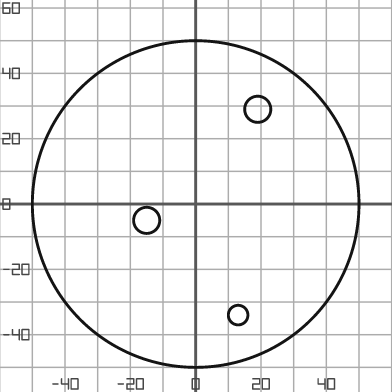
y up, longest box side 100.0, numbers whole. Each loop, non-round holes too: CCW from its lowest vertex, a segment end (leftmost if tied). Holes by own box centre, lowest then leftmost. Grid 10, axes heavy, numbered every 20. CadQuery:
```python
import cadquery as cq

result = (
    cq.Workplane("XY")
    .moveTo(0.0, 0.0)
    .circle(50.0)
    .moveTo(13.0, -34.0)
    .circle(3.0)
    .moveTo(-15.0, -5.0)
    .circle(4.0)
    .moveTo(19.0, 29.0)
    .circle(4.0)
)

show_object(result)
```